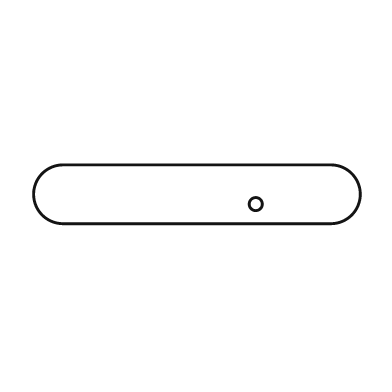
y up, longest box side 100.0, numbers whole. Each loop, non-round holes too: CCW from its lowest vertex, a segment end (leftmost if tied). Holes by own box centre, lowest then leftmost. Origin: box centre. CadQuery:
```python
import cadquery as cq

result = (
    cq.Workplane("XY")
    .moveTo(-41.0, -9.0)
    .lineTo(41.0, -9.0)
    .threePointArc((50.0, 0.0), (41.0, 9.0))
    .lineTo(-41.0, 9.0)
    .threePointArc((-50.0, 0.0), (-41.0, -9.0))
    .close()
    .moveTo(18.0, -3.0)
    .circle(2.0)
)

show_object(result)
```